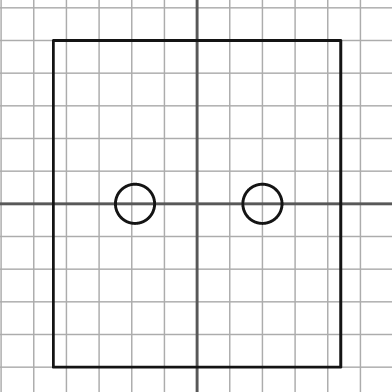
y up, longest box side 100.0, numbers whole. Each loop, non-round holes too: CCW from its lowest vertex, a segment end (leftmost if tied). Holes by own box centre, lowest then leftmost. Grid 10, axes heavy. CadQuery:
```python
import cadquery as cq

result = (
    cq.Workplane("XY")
    .moveTo(-44.0, -50.0)
    .lineTo(44.0, -50.0)
    .lineTo(44.0, 50.0)
    .lineTo(-44.0, 50.0)
    .close()
    .moveTo(-19.0, 0.0)
    .circle(6.0)
    .moveTo(20.0, 0.0)
    .circle(6.0)
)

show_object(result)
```